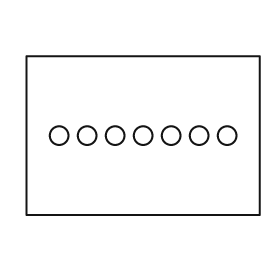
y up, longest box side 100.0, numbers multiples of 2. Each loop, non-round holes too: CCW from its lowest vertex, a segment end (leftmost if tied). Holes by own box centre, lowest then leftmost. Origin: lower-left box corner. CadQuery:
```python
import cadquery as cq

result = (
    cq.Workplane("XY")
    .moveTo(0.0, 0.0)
    .lineTo(100.0, 0.0)
    .lineTo(100.0, 68.0)
    .lineTo(0.0, 68.0)
    .close()
    .moveTo(14.0, 34.0)
    .circle(4.0)
    .moveTo(26.0, 34.0)
    .circle(4.0)
    .moveTo(38.0, 34.0)
    .circle(4.0)
    .moveTo(50.0, 34.0)
    .circle(4.0)
    .moveTo(62.0, 34.0)
    .circle(4.0)
    .moveTo(74.0, 34.0)
    .circle(4.0)
    .moveTo(86.0, 34.0)
    .circle(4.0)
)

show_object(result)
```